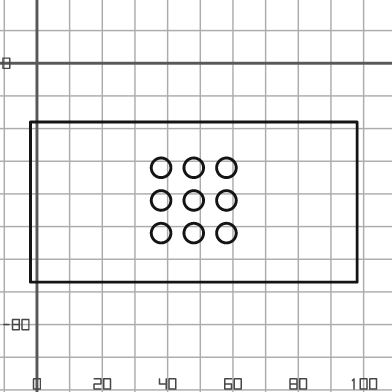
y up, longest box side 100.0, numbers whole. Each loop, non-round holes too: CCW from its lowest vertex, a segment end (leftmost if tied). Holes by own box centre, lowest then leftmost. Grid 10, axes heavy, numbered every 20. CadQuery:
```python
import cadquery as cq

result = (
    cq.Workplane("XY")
    .moveTo(-2.0, -67.0)
    .lineTo(98.0, -67.0)
    .lineTo(98.0, -18.0)
    .lineTo(-2.0, -18.0)
    .close()
    .moveTo(38.0, -52.0)
    .circle(3.0)
    .moveTo(48.0, -52.0)
    .circle(3.0)
    .moveTo(58.0, -52.0)
    .circle(3.0)
    .moveTo(38.0, -42.0)
    .circle(3.0)
    .moveTo(48.0, -42.0)
    .circle(3.0)
    .moveTo(58.0, -42.0)
    .circle(3.0)
    .moveTo(38.0, -32.0)
    .circle(3.0)
    .moveTo(48.0, -32.0)
    .circle(3.0)
    .moveTo(58.0, -32.0)
    .circle(3.0)
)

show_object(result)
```